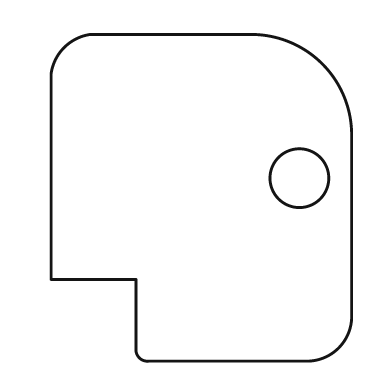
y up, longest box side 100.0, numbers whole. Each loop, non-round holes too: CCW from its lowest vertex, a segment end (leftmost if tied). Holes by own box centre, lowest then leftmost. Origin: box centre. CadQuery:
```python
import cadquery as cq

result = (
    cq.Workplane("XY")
    .moveTo(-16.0, -50.0)
    .lineTo(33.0, -50.0)
    .threePointArc((42.0, -46.0), (46.0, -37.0))
    .lineTo(46.0, 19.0)
    .threePointArc((37.0, 41.0), (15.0, 50.0))
    .lineTo(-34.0, 50.0)
    .threePointArc((-42.0, 46.0), (-46.0, 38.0))
    .lineTo(-46.0, -25.0)
    .lineTo(-20.0, -25.0)
    .lineTo(-20.0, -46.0)
    .threePointArc((-19.0, -49.0), (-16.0, -50.0))
    .close()
    .moveTo(30.0, 6.0)
    .circle(9.0)
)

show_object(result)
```